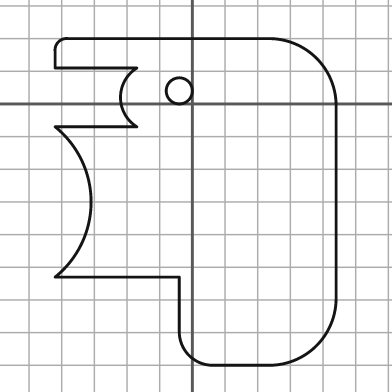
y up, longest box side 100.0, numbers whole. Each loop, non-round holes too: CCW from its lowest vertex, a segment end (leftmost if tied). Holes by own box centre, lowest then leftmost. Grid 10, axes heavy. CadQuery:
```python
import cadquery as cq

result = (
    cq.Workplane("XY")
    .moveTo(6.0, -80.0)
    .lineTo(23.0, -80.0)
    .threePointArc((38.0, -74.0), (44.0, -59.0))
    .lineTo(44.0, 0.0)
    .threePointArc((38.0, 14.0), (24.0, 20.0))
    .lineTo(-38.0, 20.0)
    .threePointArc((-41.0, 19.0), (-42.0, 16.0))
    .lineTo(-42.0, 11.0)
    .lineTo(-17.0, 11.0)
    .threePointArc((-22.0, 2.0), (-17.0, -7.0))
    .lineTo(-42.0, -7.0)
    .threePointArc((-31.0, -30.0), (-42.0, -53.0))
    .lineTo(-4.0, -53.0)
    .lineTo(-4.0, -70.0)
    .threePointArc((-1.0, -77.0), (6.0, -80.0))
    .close()
    .moveTo(-4.0, 4.0)
    .circle(4.0)
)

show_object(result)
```